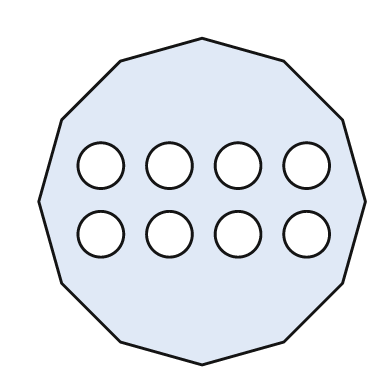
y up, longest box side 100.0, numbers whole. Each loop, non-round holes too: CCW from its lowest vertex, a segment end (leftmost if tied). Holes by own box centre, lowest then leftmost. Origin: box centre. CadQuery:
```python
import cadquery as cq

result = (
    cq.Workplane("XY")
    .moveTo(0.0, -50.0)
    .lineTo(25.0, -43.0)
    .lineTo(43.0, -25.0)
    .lineTo(50.0, 0.0)
    .lineTo(43.0, 25.0)
    .lineTo(25.0, 43.0)
    .lineTo(0.0, 50.0)
    .lineTo(-25.0, 43.0)
    .lineTo(-43.0, 25.0)
    .lineTo(-50.0, 0.0)
    .lineTo(-43.0, -25.0)
    .lineTo(-25.0, -43.0)
    .close()
    .moveTo(-31.0, -10.0)
    .circle(7.0)
    .moveTo(-10.0, -10.0)
    .circle(7.0)
    .moveTo(11.0, -10.0)
    .circle(7.0)
    .moveTo(32.0, -10.0)
    .circle(7.0)
    .moveTo(-31.0, 11.0)
    .circle(7.0)
    .moveTo(-10.0, 11.0)
    .circle(7.0)
    .moveTo(11.0, 11.0)
    .circle(7.0)
    .moveTo(32.0, 11.0)
    .circle(7.0)
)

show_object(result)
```